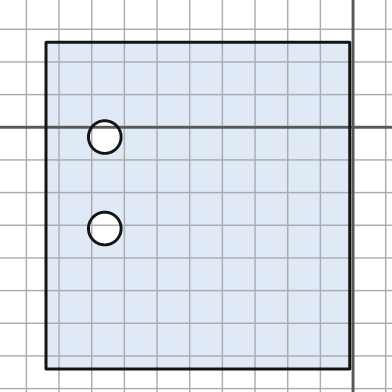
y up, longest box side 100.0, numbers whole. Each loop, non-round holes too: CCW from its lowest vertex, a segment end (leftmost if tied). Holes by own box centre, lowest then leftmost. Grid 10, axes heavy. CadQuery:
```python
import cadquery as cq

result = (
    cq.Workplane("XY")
    .moveTo(-94.0, -74.0)
    .lineTo(-1.0, -74.0)
    .lineTo(-1.0, 26.0)
    .lineTo(-94.0, 26.0)
    .close()
    .moveTo(-76.0, -31.0)
    .circle(5.0)
    .moveTo(-76.0, -3.0)
    .circle(5.0)
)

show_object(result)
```